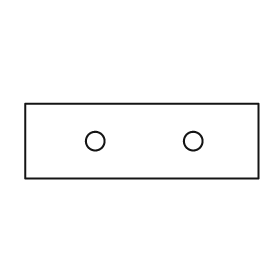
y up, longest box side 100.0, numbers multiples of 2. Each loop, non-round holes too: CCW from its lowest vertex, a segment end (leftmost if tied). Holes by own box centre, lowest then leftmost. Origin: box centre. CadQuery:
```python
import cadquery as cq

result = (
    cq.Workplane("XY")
    .moveTo(-50.0, -16.0)
    .lineTo(50.0, -16.0)
    .lineTo(50.0, 16.0)
    .lineTo(-50.0, 16.0)
    .close()
    .moveTo(-20.0, 0.0)
    .circle(4.0)
    .moveTo(22.0, 0.0)
    .circle(4.0)
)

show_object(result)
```